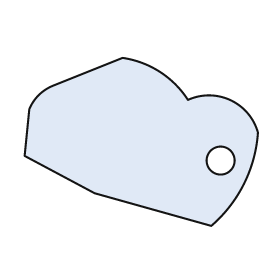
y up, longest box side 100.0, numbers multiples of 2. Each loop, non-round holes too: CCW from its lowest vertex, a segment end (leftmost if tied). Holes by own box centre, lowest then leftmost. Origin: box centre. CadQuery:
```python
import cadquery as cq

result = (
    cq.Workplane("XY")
    .moveTo(30.0, -36.0)
    .threePointArc((44.0, -18.0), (50.0, 4.0))
    .threePointArc((38.0, 18.0), (20.0, 18.0))
    .threePointArc((8.0, 30.0), (-8.0, 36.0))
    .lineTo(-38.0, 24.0)
    .threePointArc((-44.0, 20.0), (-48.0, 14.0))
    .lineTo(-50.0, -6.0)
    .lineTo(-20.0, -22.0)
    .close()
    .moveTo(34.0, -8.0)
    .circle(6.0)
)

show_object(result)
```